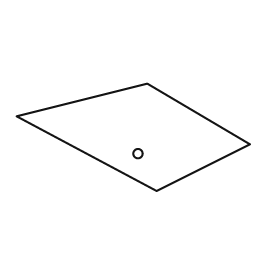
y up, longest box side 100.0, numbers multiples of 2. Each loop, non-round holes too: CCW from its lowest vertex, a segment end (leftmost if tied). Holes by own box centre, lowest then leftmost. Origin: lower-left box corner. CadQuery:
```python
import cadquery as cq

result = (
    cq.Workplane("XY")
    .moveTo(60.0, 0.0)
    .lineTo(100.0, 20.0)
    .lineTo(56.0, 46.0)
    .lineTo(0.0, 32.0)
    .close()
    .moveTo(52.0, 16.0)
    .circle(2.0)
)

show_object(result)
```